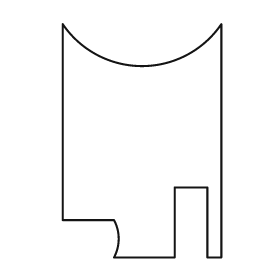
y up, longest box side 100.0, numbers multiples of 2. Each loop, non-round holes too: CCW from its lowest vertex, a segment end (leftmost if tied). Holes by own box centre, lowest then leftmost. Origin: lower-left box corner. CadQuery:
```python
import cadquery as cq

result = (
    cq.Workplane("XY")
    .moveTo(22.0, 0.0)
    .lineTo(48.0, 0.0)
    .lineTo(48.0, 30.0)
    .lineTo(62.0, 30.0)
    .lineTo(62.0, 0.0)
    .lineTo(68.0, 0.0)
    .lineTo(68.0, 100.0)
    .threePointArc((34.0, 82.0), (0.0, 100.0))
    .lineTo(0.0, 16.0)
    .lineTo(22.0, 16.0)
    .threePointArc((24.0, 8.0), (22.0, 0.0))
    .close()
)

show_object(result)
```